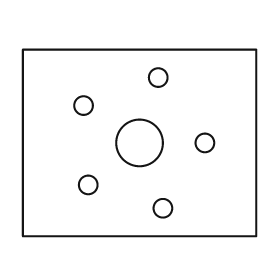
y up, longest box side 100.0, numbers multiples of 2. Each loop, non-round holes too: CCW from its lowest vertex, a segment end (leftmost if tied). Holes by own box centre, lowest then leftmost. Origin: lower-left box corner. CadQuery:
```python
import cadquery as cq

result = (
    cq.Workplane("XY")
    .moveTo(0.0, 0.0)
    .lineTo(100.0, 0.0)
    .lineTo(100.0, 80.0)
    .lineTo(0.0, 80.0)
    .close()
    .moveTo(60.0, 12.0)
    .circle(4.0)
    .moveTo(28.0, 22.0)
    .circle(4.0)
    .moveTo(50.0, 40.0)
    .circle(10.0)
    .moveTo(78.0, 40.0)
    .circle(4.0)
    .moveTo(26.0, 56.0)
    .circle(4.0)
    .moveTo(58.0, 68.0)
    .circle(4.0)
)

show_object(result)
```